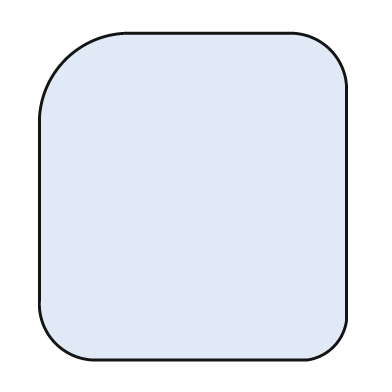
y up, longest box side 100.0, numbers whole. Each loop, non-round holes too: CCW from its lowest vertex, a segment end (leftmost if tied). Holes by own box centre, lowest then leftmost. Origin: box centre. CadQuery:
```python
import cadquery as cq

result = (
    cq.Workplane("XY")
    .moveTo(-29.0, -50.0)
    .lineTo(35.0, -50.0)
    .threePointArc((43.0, -46.0), (47.0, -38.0))
    .lineTo(47.0, 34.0)
    .threePointArc((42.0, 45.0), (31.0, 50.0))
    .lineTo(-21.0, 50.0)
    .threePointArc((-39.0, 42.0), (-47.0, 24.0))
    .lineTo(-47.0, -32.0)
    .threePointArc((-42.0, -45.0), (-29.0, -50.0))
    .close()
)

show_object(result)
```